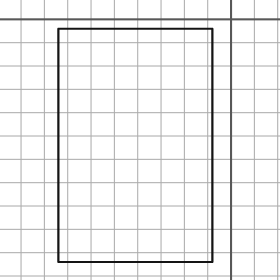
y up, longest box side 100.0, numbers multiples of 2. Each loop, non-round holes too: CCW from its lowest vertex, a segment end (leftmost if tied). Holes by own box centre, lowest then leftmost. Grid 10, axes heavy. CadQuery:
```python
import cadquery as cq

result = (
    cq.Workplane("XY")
    .moveTo(-74.0, -104.0)
    .lineTo(-8.0, -104.0)
    .lineTo(-8.0, -4.0)
    .lineTo(-74.0, -4.0)
    .close()
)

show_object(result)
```